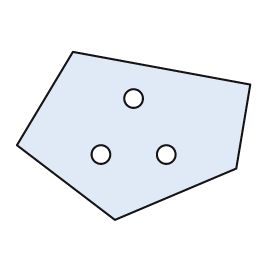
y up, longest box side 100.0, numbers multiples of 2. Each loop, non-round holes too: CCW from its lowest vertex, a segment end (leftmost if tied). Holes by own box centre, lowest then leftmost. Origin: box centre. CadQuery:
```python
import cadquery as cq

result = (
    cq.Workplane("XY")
    .moveTo(-8.0, -36.0)
    .lineTo(44.0, -14.0)
    .lineTo(50.0, 22.0)
    .lineTo(-26.0, 36.0)
    .lineTo(-50.0, -4.0)
    .close()
    .moveTo(-14.0, -8.0)
    .circle(4.0)
    .moveTo(14.0, -8.0)
    .circle(4.0)
    .moveTo(0.0, 16.0)
    .circle(4.0)
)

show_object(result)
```